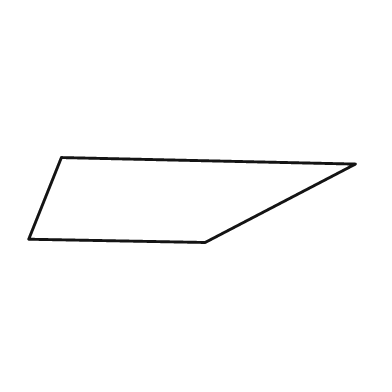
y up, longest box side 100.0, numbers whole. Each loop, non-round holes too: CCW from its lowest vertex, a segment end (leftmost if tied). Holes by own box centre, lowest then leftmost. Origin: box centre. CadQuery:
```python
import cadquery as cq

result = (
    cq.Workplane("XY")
    .moveTo(4.0, -13.0)
    .lineTo(50.0, 11.0)
    .lineTo(-40.0, 13.0)
    .lineTo(-50.0, -12.0)
    .close()
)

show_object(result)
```